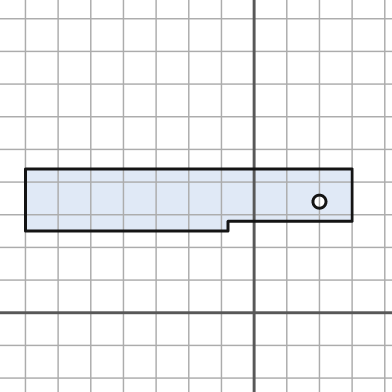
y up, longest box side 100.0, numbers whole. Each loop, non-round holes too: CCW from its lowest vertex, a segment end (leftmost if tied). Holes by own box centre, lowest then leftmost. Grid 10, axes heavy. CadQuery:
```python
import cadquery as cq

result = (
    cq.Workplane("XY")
    .moveTo(-70.0, 25.0)
    .lineTo(-8.0, 25.0)
    .lineTo(-8.0, 28.0)
    .lineTo(30.0, 28.0)
    .lineTo(30.0, 44.0)
    .lineTo(-70.0, 44.0)
    .close()
    .moveTo(20.0, 34.0)
    .circle(2.0)
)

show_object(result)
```